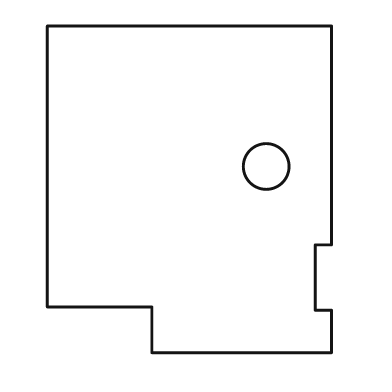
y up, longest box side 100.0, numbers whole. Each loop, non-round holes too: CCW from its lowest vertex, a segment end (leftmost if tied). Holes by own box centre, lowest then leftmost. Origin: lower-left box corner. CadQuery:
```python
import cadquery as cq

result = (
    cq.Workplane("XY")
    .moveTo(32.0, 0.0)
    .lineTo(87.0, 0.0)
    .lineTo(87.0, 13.0)
    .lineTo(82.0, 13.0)
    .lineTo(82.0, 33.0)
    .lineTo(87.0, 33.0)
    .lineTo(87.0, 100.0)
    .lineTo(0.0, 100.0)
    .lineTo(0.0, 14.0)
    .lineTo(32.0, 14.0)
    .close()
    .moveTo(67.0, 57.0)
    .circle(7.0)
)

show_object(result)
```